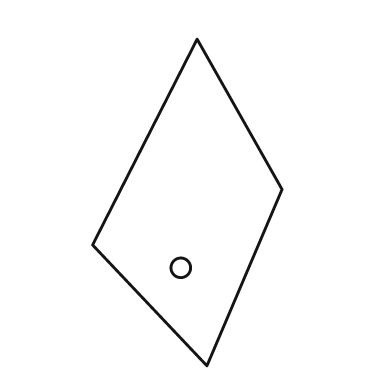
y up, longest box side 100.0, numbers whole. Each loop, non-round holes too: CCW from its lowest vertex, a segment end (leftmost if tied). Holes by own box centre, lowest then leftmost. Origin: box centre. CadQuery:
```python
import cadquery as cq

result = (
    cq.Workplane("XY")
    .moveTo(6.0, -50.0)
    .lineTo(29.0, 4.0)
    .lineTo(3.0, 50.0)
    .lineTo(-29.0, -13.0)
    .close()
    .moveTo(-2.0, -20.0)
    .circle(3.0)
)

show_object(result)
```